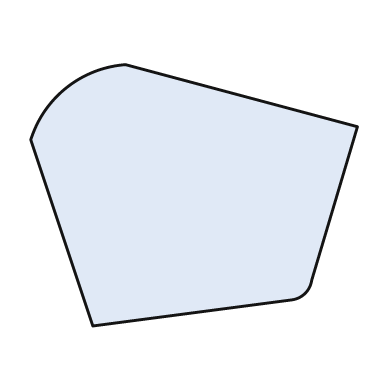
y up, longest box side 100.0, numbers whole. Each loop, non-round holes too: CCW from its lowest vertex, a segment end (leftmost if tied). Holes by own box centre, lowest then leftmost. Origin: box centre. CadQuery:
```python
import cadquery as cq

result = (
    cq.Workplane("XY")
    .moveTo(-31.0, -40.0)
    .lineTo(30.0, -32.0)
    .threePointArc((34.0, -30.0), (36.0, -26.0))
    .lineTo(50.0, 21.0)
    .lineTo(-21.0, 40.0)
    .threePointArc((-39.0, 33.0), (-50.0, 17.0))
    .close()
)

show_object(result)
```